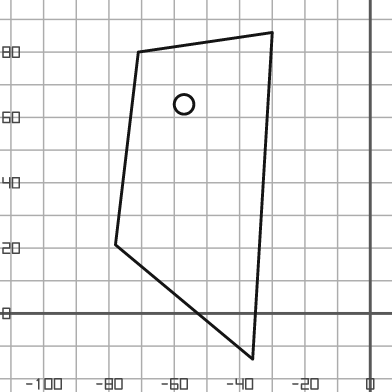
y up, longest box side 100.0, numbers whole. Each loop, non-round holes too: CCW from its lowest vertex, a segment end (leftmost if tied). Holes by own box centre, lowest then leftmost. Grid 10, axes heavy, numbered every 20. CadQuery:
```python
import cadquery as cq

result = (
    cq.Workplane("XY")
    .moveTo(-36.0, -14.0)
    .lineTo(-30.0, 86.0)
    .lineTo(-71.0, 80.0)
    .lineTo(-78.0, 21.0)
    .close()
    .moveTo(-57.0, 64.0)
    .circle(3.0)
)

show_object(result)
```